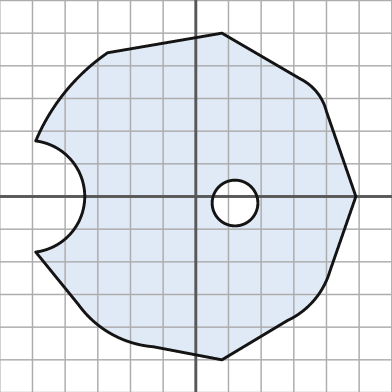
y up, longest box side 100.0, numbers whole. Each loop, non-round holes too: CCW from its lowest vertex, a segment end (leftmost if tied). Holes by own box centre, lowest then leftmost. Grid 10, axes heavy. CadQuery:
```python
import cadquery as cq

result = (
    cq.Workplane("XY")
    .moveTo(8.0, -50.0)
    .lineTo(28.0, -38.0)
    .threePointArc((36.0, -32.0), (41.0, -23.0))
    .lineTo(49.0, 0.0)
    .lineTo(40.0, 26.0)
    .threePointArc((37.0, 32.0), (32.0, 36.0))
    .lineTo(8.0, 50.0)
    .lineTo(-27.0, 44.0)
    .threePointArc((-40.0, 32.0), (-49.0, 17.0))
    .threePointArc((-34.0, 0.0), (-49.0, -17.0))
    .lineTo(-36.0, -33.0)
    .threePointArc((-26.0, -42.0), (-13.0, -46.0))
    .close()
    .moveTo(12.0, -2.0)
    .circle(7.0)
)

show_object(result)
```